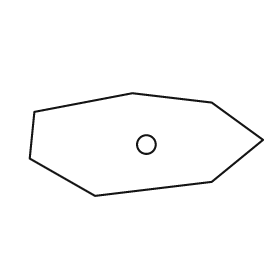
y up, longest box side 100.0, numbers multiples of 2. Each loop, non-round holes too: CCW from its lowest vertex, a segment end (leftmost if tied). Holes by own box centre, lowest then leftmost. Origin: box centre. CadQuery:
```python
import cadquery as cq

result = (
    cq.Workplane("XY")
    .moveTo(-22.0, -22.0)
    .lineTo(28.0, -16.0)
    .lineTo(50.0, 2.0)
    .lineTo(28.0, 18.0)
    .lineTo(-6.0, 22.0)
    .lineTo(-48.0, 14.0)
    .lineTo(-50.0, -6.0)
    .close()
    .moveTo(0.0, 0.0)
    .circle(4.0)
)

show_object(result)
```